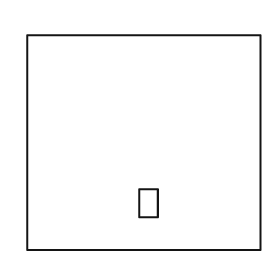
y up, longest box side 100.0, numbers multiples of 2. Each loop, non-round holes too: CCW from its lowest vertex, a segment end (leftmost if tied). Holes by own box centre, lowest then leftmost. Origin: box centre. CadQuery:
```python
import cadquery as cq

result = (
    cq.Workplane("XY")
    .moveTo(-50.0, -46.0)
    .lineTo(50.0, -46.0)
    .lineTo(50.0, 46.0)
    .lineTo(-50.0, 46.0)
    .close()
    .moveTo(-2.0, -32.0)
    .lineTo(6.0, -32.0)
    .lineTo(6.0, -20.0)
    .lineTo(-2.0, -20.0)
    .close()
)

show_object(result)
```